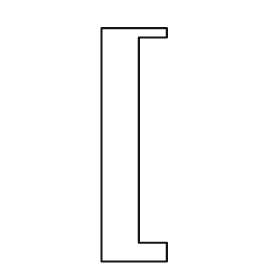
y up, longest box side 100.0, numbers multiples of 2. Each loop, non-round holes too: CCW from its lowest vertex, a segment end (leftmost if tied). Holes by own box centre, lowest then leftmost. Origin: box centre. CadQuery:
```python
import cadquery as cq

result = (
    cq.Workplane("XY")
    .moveTo(-14.0, -50.0)
    .lineTo(14.0, -50.0)
    .lineTo(14.0, -42.0)
    .lineTo(2.0, -42.0)
    .lineTo(2.0, 46.0)
    .lineTo(14.0, 46.0)
    .lineTo(14.0, 50.0)
    .lineTo(-14.0, 50.0)
    .close()
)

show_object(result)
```